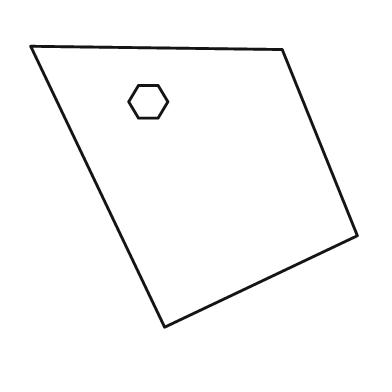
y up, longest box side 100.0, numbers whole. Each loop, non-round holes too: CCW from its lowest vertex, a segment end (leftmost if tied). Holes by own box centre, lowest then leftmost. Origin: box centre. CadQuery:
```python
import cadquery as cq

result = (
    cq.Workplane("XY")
    .moveTo(-9.0, -43.0)
    .lineTo(50.0, -15.0)
    .lineTo(27.0, 42.0)
    .lineTo(-50.0, 43.0)
    .close()
    .moveTo(-17.0, 21.0)
    .lineTo(-11.0, 21.0)
    .lineTo(-8.0, 26.0)
    .lineTo(-11.0, 31.0)
    .lineTo(-17.0, 31.0)
    .lineTo(-20.0, 26.0)
    .close()
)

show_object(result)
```